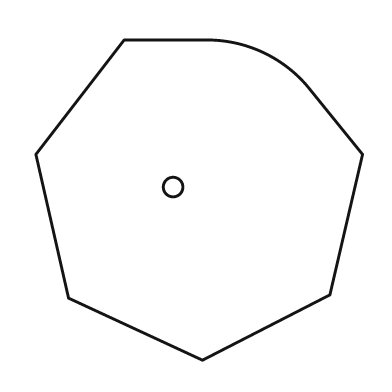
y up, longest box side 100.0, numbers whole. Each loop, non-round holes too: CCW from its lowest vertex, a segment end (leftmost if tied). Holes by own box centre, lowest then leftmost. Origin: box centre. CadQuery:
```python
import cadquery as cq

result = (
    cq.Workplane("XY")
    .moveTo(1.0, -49.0)
    .lineTo(40.0, -29.0)
    .lineTo(50.0, 14.0)
    .lineTo(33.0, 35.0)
    .threePointArc((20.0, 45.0), (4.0, 49.0))
    .lineTo(-23.0, 49.0)
    .lineTo(-50.0, 14.0)
    .lineTo(-40.0, -30.0)
    .close()
    .moveTo(-8.0, 4.0)
    .circle(3.0)
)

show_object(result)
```